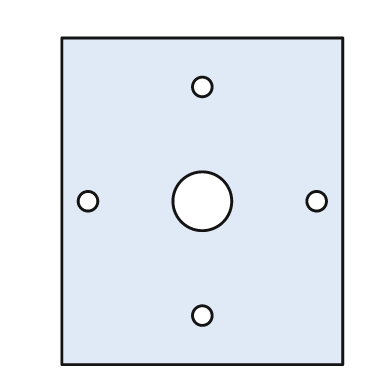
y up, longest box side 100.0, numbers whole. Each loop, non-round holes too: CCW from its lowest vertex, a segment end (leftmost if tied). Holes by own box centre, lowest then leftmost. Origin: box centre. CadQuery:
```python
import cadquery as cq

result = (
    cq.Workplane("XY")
    .moveTo(-43.0, -50.0)
    .lineTo(43.0, -50.0)
    .lineTo(43.0, 50.0)
    .lineTo(-43.0, 50.0)
    .close()
    .moveTo(0.0, -35.0)
    .circle(3.0)
    .moveTo(-35.0, 0.0)
    .circle(3.0)
    .moveTo(0.0, 0.0)
    .circle(9.0)
    .moveTo(35.0, 0.0)
    .circle(3.0)
    .moveTo(0.0, 35.0)
    .circle(3.0)
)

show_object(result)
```